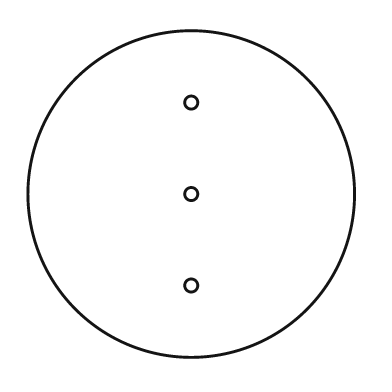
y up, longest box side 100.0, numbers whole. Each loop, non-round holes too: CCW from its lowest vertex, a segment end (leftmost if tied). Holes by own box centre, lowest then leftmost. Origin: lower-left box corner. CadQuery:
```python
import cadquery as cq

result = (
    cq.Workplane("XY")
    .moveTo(50.0, 50.0)
    .circle(50.0)
    .moveTo(50.0, 22.0)
    .circle(2.0)
    .moveTo(50.0, 50.0)
    .circle(2.0)
    .moveTo(50.0, 78.0)
    .circle(2.0)
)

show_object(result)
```